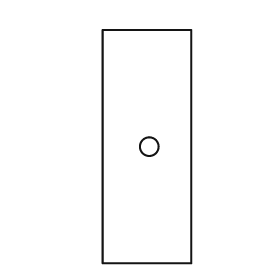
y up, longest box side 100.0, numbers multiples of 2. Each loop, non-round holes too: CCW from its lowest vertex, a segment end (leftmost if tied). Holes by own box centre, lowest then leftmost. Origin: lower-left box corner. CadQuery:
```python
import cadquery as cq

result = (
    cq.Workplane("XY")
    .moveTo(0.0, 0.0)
    .lineTo(38.0, 0.0)
    .lineTo(38.0, 100.0)
    .lineTo(0.0, 100.0)
    .close()
    .moveTo(20.0, 50.0)
    .circle(4.0)
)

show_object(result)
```